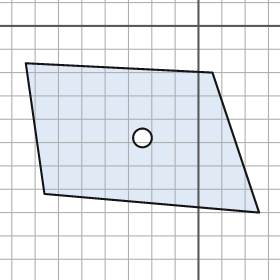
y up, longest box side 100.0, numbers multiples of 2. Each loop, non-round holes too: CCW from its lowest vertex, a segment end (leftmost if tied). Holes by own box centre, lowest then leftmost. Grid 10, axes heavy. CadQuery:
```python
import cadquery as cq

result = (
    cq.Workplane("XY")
    .moveTo(26.0, -80.0)
    .lineTo(6.0, -20.0)
    .lineTo(-74.0, -16.0)
    .lineTo(-66.0, -72.0)
    .close()
    .moveTo(-24.0, -48.0)
    .circle(4.0)
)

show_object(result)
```